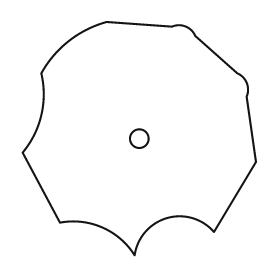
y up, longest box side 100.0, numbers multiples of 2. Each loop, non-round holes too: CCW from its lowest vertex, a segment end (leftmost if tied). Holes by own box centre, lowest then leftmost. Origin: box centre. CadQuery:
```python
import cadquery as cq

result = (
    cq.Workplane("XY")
    .moveTo(-2.0, -50.0)
    .threePointArc((12.0, -34.0), (32.0, -40.0))
    .lineTo(50.0, -10.0)
    .lineTo(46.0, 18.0)
    .threePointArc((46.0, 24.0), (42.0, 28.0))
    .lineTo(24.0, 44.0)
    .threePointArc((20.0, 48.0), (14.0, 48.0))
    .lineTo(-14.0, 50.0)
    .threePointArc((-30.0, 42.0), (-42.0, 28.0))
    .threePointArc((-42.0, 10.0), (-50.0, -6.0))
    .lineTo(-34.0, -36.0)
    .threePointArc((-16.0, -38.0), (-2.0, -50.0))
    .close()
    .moveTo(0.0, 0.0)
    .circle(4.0)
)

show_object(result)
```